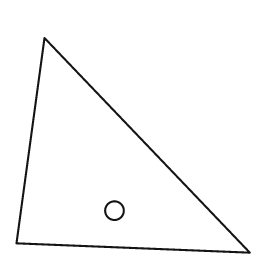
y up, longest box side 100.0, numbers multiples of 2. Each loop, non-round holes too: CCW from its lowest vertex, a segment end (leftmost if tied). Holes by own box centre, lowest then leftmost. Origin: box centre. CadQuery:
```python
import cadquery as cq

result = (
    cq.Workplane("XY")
    .moveTo(50.0, -46.0)
    .lineTo(-38.0, 46.0)
    .lineTo(-50.0, -42.0)
    .close()
    .moveTo(-8.0, -28.0)
    .circle(4.0)
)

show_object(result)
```